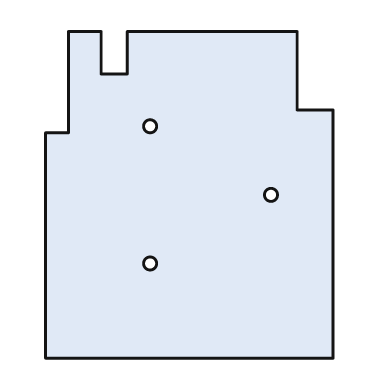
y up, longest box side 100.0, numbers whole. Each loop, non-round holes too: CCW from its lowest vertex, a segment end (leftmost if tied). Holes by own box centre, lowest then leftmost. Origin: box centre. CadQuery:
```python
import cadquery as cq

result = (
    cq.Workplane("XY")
    .moveTo(-44.0, -50.0)
    .lineTo(44.0, -50.0)
    .lineTo(44.0, 26.0)
    .lineTo(33.0, 26.0)
    .lineTo(33.0, 50.0)
    .lineTo(-19.0, 50.0)
    .lineTo(-19.0, 37.0)
    .lineTo(-27.0, 37.0)
    .lineTo(-27.0, 50.0)
    .lineTo(-37.0, 50.0)
    .lineTo(-37.0, 19.0)
    .lineTo(-44.0, 19.0)
    .close()
    .moveTo(-12.0, -21.0)
    .circle(2.0)
    .moveTo(25.0, 0.0)
    .circle(2.0)
    .moveTo(-12.0, 21.0)
    .circle(2.0)
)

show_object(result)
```